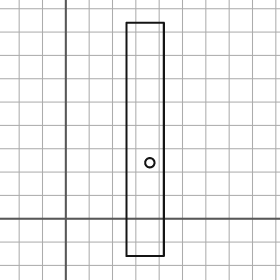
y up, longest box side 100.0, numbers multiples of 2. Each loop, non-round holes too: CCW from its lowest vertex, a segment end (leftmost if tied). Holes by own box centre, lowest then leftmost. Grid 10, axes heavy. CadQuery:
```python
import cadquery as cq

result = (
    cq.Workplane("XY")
    .moveTo(26.0, -16.0)
    .lineTo(42.0, -16.0)
    .lineTo(42.0, 84.0)
    .lineTo(26.0, 84.0)
    .close()
    .moveTo(36.0, 24.0)
    .circle(2.0)
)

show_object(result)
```